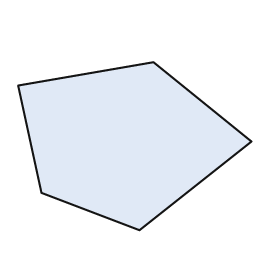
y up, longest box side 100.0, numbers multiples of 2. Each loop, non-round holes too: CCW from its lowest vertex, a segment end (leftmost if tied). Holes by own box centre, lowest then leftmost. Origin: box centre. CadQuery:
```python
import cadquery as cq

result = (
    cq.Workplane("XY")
    .moveTo(2.0, -36.0)
    .lineTo(50.0, 2.0)
    .lineTo(8.0, 36.0)
    .lineTo(-50.0, 26.0)
    .lineTo(-40.0, -20.0)
    .close()
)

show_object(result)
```